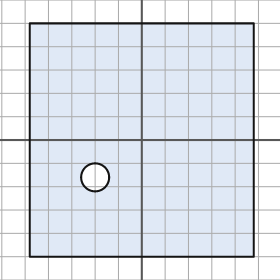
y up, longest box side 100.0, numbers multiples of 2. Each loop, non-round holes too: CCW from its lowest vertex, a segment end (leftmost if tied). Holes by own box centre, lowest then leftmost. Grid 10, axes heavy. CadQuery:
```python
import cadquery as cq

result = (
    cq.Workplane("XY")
    .moveTo(-48.0, -50.0)
    .lineTo(48.0, -50.0)
    .lineTo(48.0, 50.0)
    .lineTo(-48.0, 50.0)
    .close()
    .moveTo(-20.0, -16.0)
    .circle(6.0)
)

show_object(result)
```